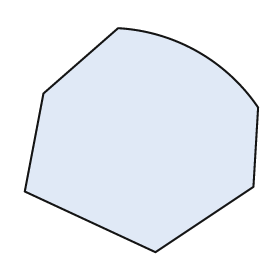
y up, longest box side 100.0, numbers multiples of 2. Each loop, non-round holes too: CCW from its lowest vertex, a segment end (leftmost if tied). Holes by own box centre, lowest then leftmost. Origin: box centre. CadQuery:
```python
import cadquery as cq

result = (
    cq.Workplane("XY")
    .moveTo(6.0, -48.0)
    .lineTo(48.0, -20.0)
    .lineTo(50.0, 14.0)
    .threePointArc((24.0, 38.0), (-10.0, 48.0))
    .lineTo(-42.0, 20.0)
    .lineTo(-50.0, -22.0)
    .close()
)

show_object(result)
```